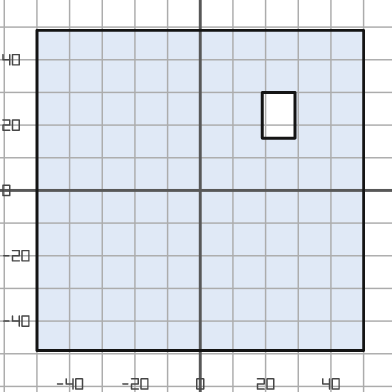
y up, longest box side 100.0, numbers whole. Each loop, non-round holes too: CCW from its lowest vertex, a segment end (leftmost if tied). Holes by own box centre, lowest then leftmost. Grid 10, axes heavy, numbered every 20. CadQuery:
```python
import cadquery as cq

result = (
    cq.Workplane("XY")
    .moveTo(-50.0, -49.0)
    .lineTo(50.0, -49.0)
    .lineTo(50.0, 49.0)
    .lineTo(-50.0, 49.0)
    .close()
    .moveTo(19.0, 16.0)
    .lineTo(29.0, 16.0)
    .lineTo(29.0, 30.0)
    .lineTo(19.0, 30.0)
    .close()
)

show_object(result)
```